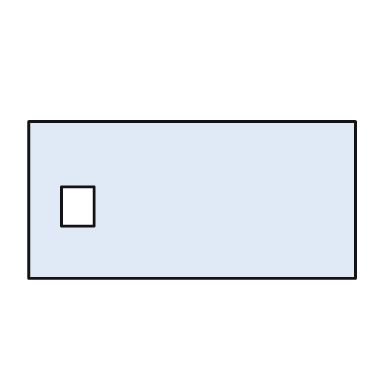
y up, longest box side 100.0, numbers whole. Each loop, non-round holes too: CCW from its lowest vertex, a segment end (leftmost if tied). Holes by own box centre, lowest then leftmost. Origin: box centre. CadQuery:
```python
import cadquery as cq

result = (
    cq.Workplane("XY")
    .moveTo(-50.0, -24.0)
    .lineTo(50.0, -24.0)
    .lineTo(50.0, 24.0)
    .lineTo(-50.0, 24.0)
    .close()
    .moveTo(-40.0, -8.0)
    .lineTo(-30.0, -8.0)
    .lineTo(-30.0, 4.0)
    .lineTo(-40.0, 4.0)
    .close()
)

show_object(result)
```